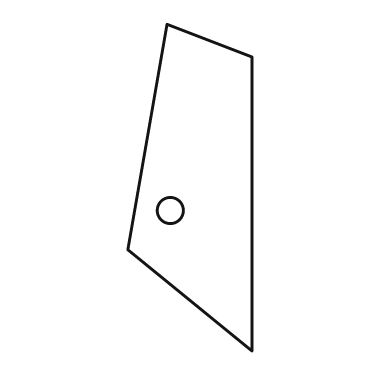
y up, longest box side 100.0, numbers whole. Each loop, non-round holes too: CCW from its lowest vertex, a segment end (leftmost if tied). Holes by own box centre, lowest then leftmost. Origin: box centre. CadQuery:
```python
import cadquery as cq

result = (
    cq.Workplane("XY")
    .moveTo(19.0, -50.0)
    .lineTo(19.0, 40.0)
    .lineTo(-7.0, 50.0)
    .lineTo(-19.0, -19.0)
    .close()
    .moveTo(-6.0, -7.0)
    .circle(4.0)
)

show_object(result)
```